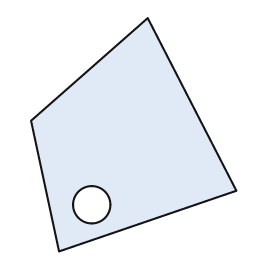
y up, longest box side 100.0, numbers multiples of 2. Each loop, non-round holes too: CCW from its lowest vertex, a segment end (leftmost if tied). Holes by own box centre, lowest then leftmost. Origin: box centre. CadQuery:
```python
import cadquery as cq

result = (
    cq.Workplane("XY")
    .moveTo(-32.0, -50.0)
    .lineTo(44.0, -24.0)
    .lineTo(6.0, 50.0)
    .lineTo(-44.0, 6.0)
    .close()
    .moveTo(-18.0, -30.0)
    .circle(8.0)
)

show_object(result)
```